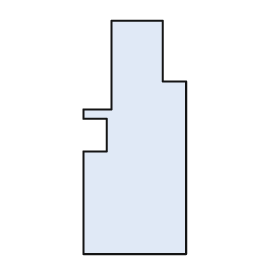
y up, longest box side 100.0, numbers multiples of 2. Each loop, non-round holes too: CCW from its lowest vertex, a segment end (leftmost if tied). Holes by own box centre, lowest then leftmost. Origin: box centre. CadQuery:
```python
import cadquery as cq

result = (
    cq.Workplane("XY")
    .moveTo(-22.0, -50.0)
    .lineTo(22.0, -50.0)
    .lineTo(22.0, 24.0)
    .lineTo(12.0, 24.0)
    .lineTo(12.0, 50.0)
    .lineTo(-10.0, 50.0)
    .lineTo(-10.0, 12.0)
    .lineTo(-22.0, 12.0)
    .lineTo(-22.0, 8.0)
    .lineTo(-12.0, 8.0)
    .lineTo(-12.0, -6.0)
    .lineTo(-22.0, -6.0)
    .close()
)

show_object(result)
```